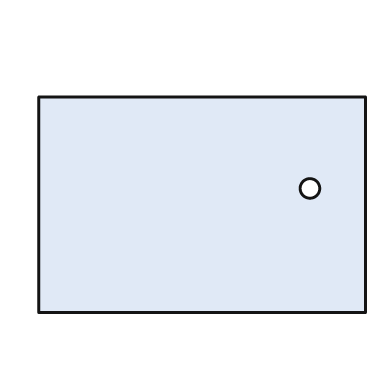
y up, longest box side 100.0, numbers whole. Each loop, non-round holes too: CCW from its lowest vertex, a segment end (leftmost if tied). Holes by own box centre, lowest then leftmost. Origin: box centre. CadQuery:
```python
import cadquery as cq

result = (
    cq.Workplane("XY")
    .moveTo(-50.0, -33.0)
    .lineTo(50.0, -33.0)
    .lineTo(50.0, 33.0)
    .lineTo(-50.0, 33.0)
    .close()
    .moveTo(33.0, 5.0)
    .circle(3.0)
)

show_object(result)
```